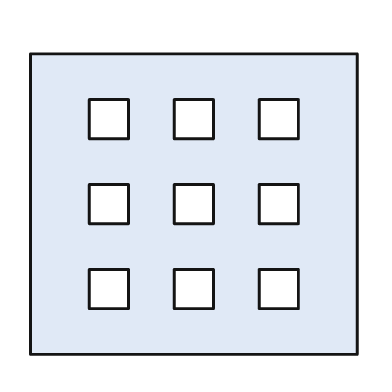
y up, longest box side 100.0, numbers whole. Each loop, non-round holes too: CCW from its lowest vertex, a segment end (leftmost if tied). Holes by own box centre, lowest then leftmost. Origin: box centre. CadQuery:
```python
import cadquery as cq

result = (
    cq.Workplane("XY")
    .moveTo(-50.0, -46.0)
    .lineTo(50.0, -46.0)
    .lineTo(50.0, 46.0)
    .lineTo(-50.0, 46.0)
    .close()
    .moveTo(-32.0, -32.0)
    .lineTo(-20.0, -32.0)
    .lineTo(-20.0, -20.0)
    .lineTo(-32.0, -20.0)
    .close()
    .moveTo(-6.0, -32.0)
    .lineTo(6.0, -32.0)
    .lineTo(6.0, -20.0)
    .lineTo(-6.0, -20.0)
    .close()
    .moveTo(20.0, -32.0)
    .lineTo(32.0, -32.0)
    .lineTo(32.0, -20.0)
    .lineTo(20.0, -20.0)
    .close()
    .moveTo(-32.0, -6.0)
    .lineTo(-20.0, -6.0)
    .lineTo(-20.0, 6.0)
    .lineTo(-32.0, 6.0)
    .close()
    .moveTo(-6.0, -6.0)
    .lineTo(6.0, -6.0)
    .lineTo(6.0, 6.0)
    .lineTo(-6.0, 6.0)
    .close()
    .moveTo(20.0, -6.0)
    .lineTo(32.0, -6.0)
    .lineTo(32.0, 6.0)
    .lineTo(20.0, 6.0)
    .close()
    .moveTo(-32.0, 20.0)
    .lineTo(-20.0, 20.0)
    .lineTo(-20.0, 32.0)
    .lineTo(-32.0, 32.0)
    .close()
    .moveTo(-6.0, 20.0)
    .lineTo(6.0, 20.0)
    .lineTo(6.0, 32.0)
    .lineTo(-6.0, 32.0)
    .close()
    .moveTo(20.0, 20.0)
    .lineTo(32.0, 20.0)
    .lineTo(32.0, 32.0)
    .lineTo(20.0, 32.0)
    .close()
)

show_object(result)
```